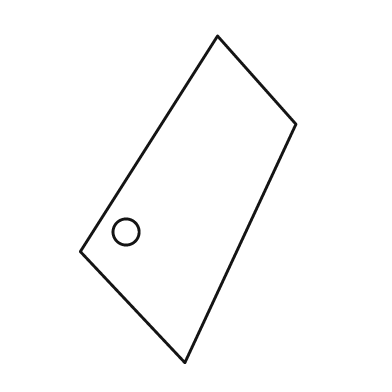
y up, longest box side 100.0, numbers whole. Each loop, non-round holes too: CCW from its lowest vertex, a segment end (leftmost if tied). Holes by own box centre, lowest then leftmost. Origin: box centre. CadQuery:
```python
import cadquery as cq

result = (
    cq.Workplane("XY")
    .moveTo(-1.0, -50.0)
    .lineTo(33.0, 23.0)
    .lineTo(9.0, 50.0)
    .lineTo(-33.0, -16.0)
    .close()
    .moveTo(-19.0, -10.0)
    .circle(4.0)
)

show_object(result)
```